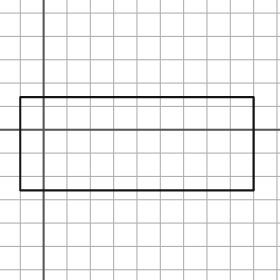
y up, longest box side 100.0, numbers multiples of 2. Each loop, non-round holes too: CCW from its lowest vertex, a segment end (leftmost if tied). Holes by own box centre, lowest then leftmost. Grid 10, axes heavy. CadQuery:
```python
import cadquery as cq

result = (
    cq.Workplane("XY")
    .moveTo(-10.0, -26.0)
    .lineTo(90.0, -26.0)
    .lineTo(90.0, 14.0)
    .lineTo(-10.0, 14.0)
    .close()
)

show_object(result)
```